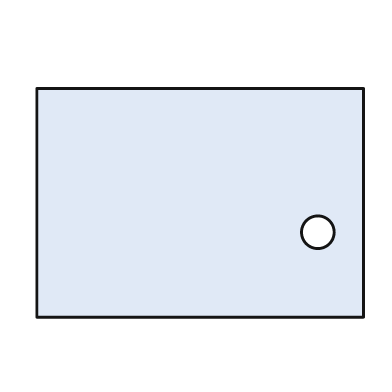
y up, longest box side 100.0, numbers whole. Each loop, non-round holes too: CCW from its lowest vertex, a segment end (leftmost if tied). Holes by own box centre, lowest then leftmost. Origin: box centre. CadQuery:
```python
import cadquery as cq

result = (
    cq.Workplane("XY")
    .moveTo(-50.0, -35.0)
    .lineTo(50.0, -35.0)
    .lineTo(50.0, 35.0)
    .lineTo(-50.0, 35.0)
    .close()
    .moveTo(36.0, -9.0)
    .circle(5.0)
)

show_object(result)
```